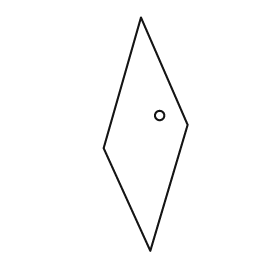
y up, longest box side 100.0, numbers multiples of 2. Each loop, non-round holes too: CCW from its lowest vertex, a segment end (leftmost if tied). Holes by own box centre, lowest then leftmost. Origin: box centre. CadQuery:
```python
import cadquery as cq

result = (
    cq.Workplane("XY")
    .moveTo(2.0, -50.0)
    .lineTo(18.0, 4.0)
    .lineTo(-2.0, 50.0)
    .lineTo(-18.0, -6.0)
    .close()
    .moveTo(6.0, 8.0)
    .circle(2.0)
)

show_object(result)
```